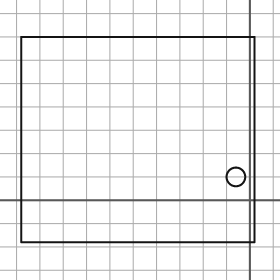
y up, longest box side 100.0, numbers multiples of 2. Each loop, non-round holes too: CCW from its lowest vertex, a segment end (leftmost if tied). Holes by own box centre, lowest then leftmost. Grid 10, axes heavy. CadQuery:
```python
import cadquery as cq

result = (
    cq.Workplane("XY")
    .moveTo(-98.0, -18.0)
    .lineTo(2.0, -18.0)
    .lineTo(2.0, 70.0)
    .lineTo(-98.0, 70.0)
    .close()
    .moveTo(-6.0, 10.0)
    .circle(4.0)
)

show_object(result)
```